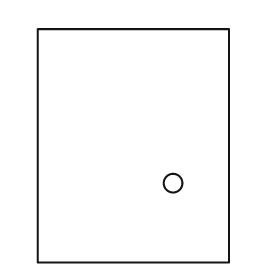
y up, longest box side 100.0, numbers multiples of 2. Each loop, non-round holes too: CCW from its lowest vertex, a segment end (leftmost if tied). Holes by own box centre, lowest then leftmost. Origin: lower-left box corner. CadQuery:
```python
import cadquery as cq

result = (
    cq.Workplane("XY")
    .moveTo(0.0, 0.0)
    .lineTo(82.0, 0.0)
    .lineTo(82.0, 100.0)
    .lineTo(0.0, 100.0)
    .close()
    .moveTo(58.0, 34.0)
    .circle(4.0)
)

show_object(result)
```